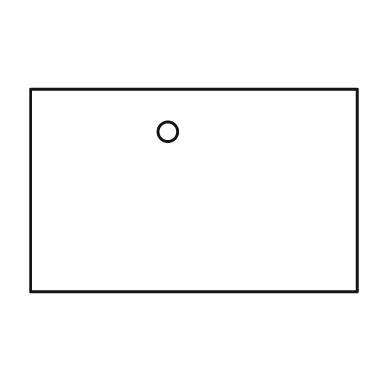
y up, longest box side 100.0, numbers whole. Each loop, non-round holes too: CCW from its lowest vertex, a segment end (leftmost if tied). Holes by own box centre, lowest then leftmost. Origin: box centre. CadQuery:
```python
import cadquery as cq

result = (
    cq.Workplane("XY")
    .moveTo(-50.0, -31.0)
    .lineTo(50.0, -31.0)
    .lineTo(50.0, 31.0)
    .lineTo(-50.0, 31.0)
    .close()
    .moveTo(-8.0, 18.0)
    .circle(3.0)
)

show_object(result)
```